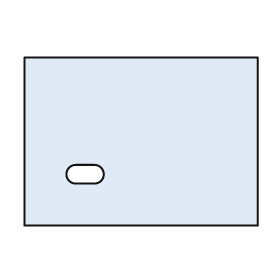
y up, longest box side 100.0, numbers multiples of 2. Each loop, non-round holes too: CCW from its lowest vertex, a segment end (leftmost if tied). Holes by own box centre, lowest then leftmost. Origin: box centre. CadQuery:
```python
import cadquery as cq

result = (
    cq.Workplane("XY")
    .moveTo(-50.0, -36.0)
    .lineTo(50.0, -36.0)
    .lineTo(50.0, 36.0)
    .lineTo(-50.0, 36.0)
    .close()
    .moveTo(-28.0, -18.0)
    .lineTo(-20.0, -18.0)
    .threePointArc((-16.0, -14.0), (-20.0, -10.0))
    .lineTo(-28.0, -10.0)
    .threePointArc((-32.0, -14.0), (-28.0, -18.0))
    .close()
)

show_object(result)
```